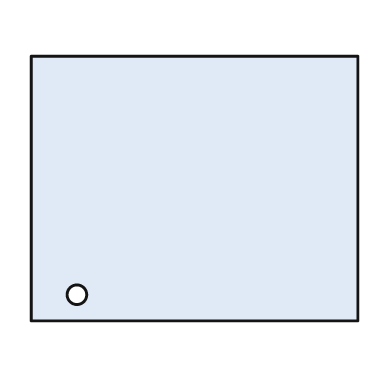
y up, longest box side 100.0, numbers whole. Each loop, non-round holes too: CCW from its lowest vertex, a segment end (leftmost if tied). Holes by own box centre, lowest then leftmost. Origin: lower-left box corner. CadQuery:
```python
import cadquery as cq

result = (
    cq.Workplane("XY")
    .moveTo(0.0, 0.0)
    .lineTo(100.0, 0.0)
    .lineTo(100.0, 81.0)
    .lineTo(0.0, 81.0)
    .close()
    .moveTo(14.0, 8.0)
    .circle(3.0)
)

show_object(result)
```